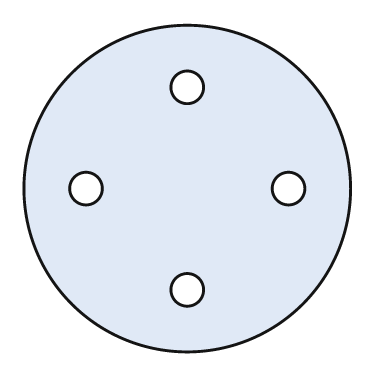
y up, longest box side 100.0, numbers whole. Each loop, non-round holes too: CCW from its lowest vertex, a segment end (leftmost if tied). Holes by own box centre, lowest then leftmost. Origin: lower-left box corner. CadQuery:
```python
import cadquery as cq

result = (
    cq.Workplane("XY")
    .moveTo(50.0, 50.0)
    .circle(50.0)
    .moveTo(50.0, 19.0)
    .circle(5.0)
    .moveTo(19.0, 50.0)
    .circle(5.0)
    .moveTo(81.0, 50.0)
    .circle(5.0)
    .moveTo(50.0, 81.0)
    .circle(5.0)
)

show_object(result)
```